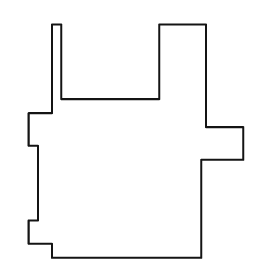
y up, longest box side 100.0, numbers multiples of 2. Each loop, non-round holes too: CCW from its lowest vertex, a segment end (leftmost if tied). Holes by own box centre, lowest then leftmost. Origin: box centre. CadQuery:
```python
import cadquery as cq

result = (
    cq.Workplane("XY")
    .moveTo(-36.0, -50.0)
    .lineTo(28.0, -50.0)
    .lineTo(28.0, -8.0)
    .lineTo(46.0, -8.0)
    .lineTo(46.0, 6.0)
    .lineTo(30.0, 6.0)
    .lineTo(30.0, 50.0)
    .lineTo(10.0, 50.0)
    .lineTo(10.0, 18.0)
    .lineTo(-32.0, 18.0)
    .lineTo(-32.0, 50.0)
    .lineTo(-36.0, 50.0)
    .lineTo(-36.0, 12.0)
    .lineTo(-46.0, 12.0)
    .lineTo(-46.0, -2.0)
    .lineTo(-42.0, -2.0)
    .lineTo(-42.0, -34.0)
    .lineTo(-46.0, -34.0)
    .lineTo(-46.0, -44.0)
    .lineTo(-36.0, -44.0)
    .close()
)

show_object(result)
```